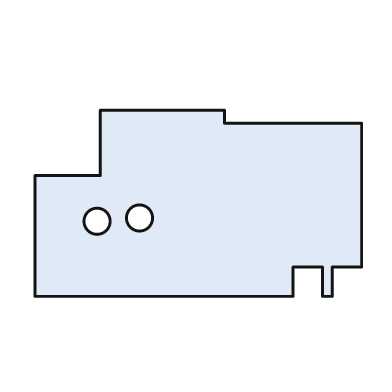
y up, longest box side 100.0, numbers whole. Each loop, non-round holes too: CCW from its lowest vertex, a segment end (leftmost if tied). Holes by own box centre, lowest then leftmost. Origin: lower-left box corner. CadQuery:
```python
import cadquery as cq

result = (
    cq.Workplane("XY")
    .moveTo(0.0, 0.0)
    .lineTo(79.0, 0.0)
    .lineTo(79.0, 9.0)
    .lineTo(88.0, 9.0)
    .lineTo(88.0, 0.0)
    .lineTo(91.0, 0.0)
    .lineTo(91.0, 9.0)
    .lineTo(100.0, 9.0)
    .lineTo(100.0, 53.0)
    .lineTo(58.0, 53.0)
    .lineTo(58.0, 57.0)
    .lineTo(20.0, 57.0)
    .lineTo(20.0, 37.0)
    .lineTo(0.0, 37.0)
    .close()
    .moveTo(19.0, 23.0)
    .circle(4.0)
    .moveTo(32.0, 24.0)
    .circle(4.0)
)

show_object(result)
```